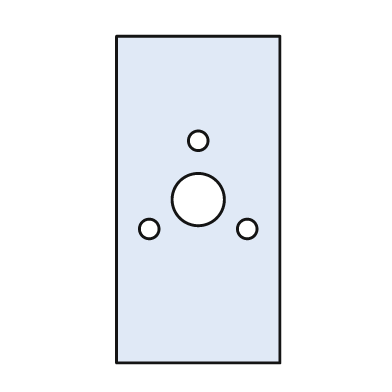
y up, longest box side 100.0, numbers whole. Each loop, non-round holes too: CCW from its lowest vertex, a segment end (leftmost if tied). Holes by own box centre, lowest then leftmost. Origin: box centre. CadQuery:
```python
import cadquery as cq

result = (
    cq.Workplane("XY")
    .moveTo(-25.0, -50.0)
    .lineTo(25.0, -50.0)
    .lineTo(25.0, 50.0)
    .lineTo(-25.0, 50.0)
    .close()
    .moveTo(-15.0, -9.0)
    .circle(3.0)
    .moveTo(15.0, -9.0)
    .circle(3.0)
    .moveTo(0.0, 0.0)
    .circle(8.0)
    .moveTo(0.0, 18.0)
    .circle(3.0)
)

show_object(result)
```